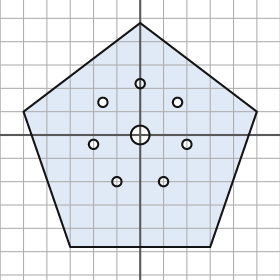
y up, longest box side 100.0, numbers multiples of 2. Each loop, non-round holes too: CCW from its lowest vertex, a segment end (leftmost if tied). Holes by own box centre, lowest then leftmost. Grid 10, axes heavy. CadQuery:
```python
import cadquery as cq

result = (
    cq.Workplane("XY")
    .moveTo(-30.0, -48.0)
    .lineTo(30.0, -48.0)
    .lineTo(50.0, 10.0)
    .lineTo(0.0, 48.0)
    .lineTo(-50.0, 10.0)
    .close()
    .moveTo(-10.0, -20.0)
    .circle(2.0)
    .moveTo(10.0, -20.0)
    .circle(2.0)
    .moveTo(-20.0, -4.0)
    .circle(2.0)
    .moveTo(20.0, -4.0)
    .circle(2.0)
    .moveTo(0.0, 0.0)
    .circle(4.0)
    .moveTo(-16.0, 14.0)
    .circle(2.0)
    .moveTo(16.0, 14.0)
    .circle(2.0)
    .moveTo(0.0, 22.0)
    .circle(2.0)
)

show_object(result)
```